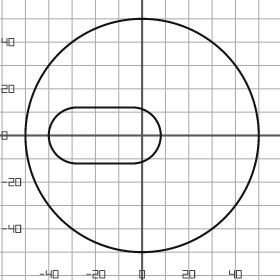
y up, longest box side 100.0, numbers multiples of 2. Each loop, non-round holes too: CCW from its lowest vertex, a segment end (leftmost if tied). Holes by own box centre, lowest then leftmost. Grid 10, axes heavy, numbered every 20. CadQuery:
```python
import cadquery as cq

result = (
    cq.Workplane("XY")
    .moveTo(0.0, 0.0)
    .circle(50.0)
    .moveTo(-28.0, -12.0)
    .lineTo(-4.0, -12.0)
    .threePointArc((8.0, 0.0), (-4.0, 12.0))
    .lineTo(-28.0, 12.0)
    .threePointArc((-40.0, 0.0), (-28.0, -12.0))
    .close()
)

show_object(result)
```